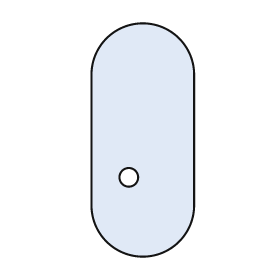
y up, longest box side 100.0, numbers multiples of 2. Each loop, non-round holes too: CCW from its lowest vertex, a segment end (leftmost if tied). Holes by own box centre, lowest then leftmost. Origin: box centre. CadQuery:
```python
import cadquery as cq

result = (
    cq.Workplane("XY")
    .moveTo(-22.0, -28.0)
    .threePointArc((0.0, -50.0), (22.0, -28.0))
    .lineTo(22.0, 28.0)
    .threePointArc((0.0, 50.0), (-22.0, 28.0))
    .close()
    .moveTo(-6.0, -16.0)
    .circle(4.0)
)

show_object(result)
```